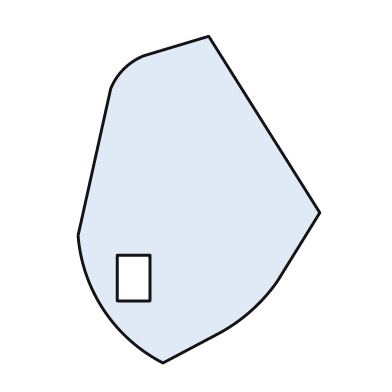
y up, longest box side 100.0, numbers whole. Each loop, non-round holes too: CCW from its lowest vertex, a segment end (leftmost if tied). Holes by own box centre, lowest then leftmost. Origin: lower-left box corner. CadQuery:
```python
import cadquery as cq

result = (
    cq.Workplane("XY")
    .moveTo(26.0, 0.0)
    .lineTo(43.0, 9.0)
    .threePointArc((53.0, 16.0), (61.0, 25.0))
    .lineTo(74.0, 46.0)
    .lineTo(40.0, 100.0)
    .lineTo(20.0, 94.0)
    .threePointArc((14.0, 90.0), (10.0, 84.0))
    .lineTo(0.0, 39.0)
    .threePointArc((8.0, 16.0), (26.0, 0.0))
    .close()
    .moveTo(12.0, 19.0)
    .lineTo(22.0, 19.0)
    .lineTo(22.0, 33.0)
    .lineTo(12.0, 33.0)
    .close()
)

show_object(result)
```